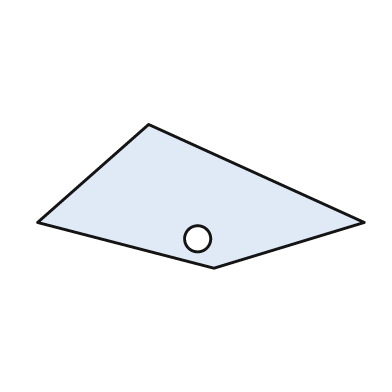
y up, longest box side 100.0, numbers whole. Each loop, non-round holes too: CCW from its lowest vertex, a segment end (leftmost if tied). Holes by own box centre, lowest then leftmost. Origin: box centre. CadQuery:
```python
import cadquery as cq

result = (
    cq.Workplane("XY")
    .moveTo(4.0, -22.0)
    .lineTo(50.0, -8.0)
    .lineTo(-16.0, 22.0)
    .lineTo(-50.0, -8.0)
    .close()
    .moveTo(-1.0, -13.0)
    .circle(4.0)
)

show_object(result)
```